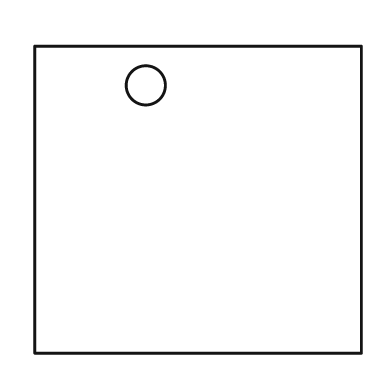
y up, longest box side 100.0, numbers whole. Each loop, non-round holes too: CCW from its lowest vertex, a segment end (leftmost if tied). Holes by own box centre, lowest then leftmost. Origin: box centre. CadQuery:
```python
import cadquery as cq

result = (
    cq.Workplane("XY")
    .moveTo(-50.0, -47.0)
    .lineTo(50.0, -47.0)
    .lineTo(50.0, 47.0)
    .lineTo(-50.0, 47.0)
    .close()
    .moveTo(-16.0, 35.0)
    .circle(6.0)
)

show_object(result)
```